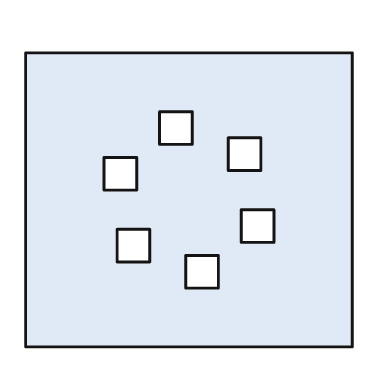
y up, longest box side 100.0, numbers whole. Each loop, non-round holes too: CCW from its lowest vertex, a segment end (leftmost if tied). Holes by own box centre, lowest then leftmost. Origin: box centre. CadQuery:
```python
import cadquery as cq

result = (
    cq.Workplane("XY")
    .moveTo(-50.0, -45.0)
    .lineTo(50.0, -45.0)
    .lineTo(50.0, 45.0)
    .lineTo(-50.0, 45.0)
    .close()
    .moveTo(-1.0, -27.0)
    .lineTo(9.0, -27.0)
    .lineTo(9.0, -17.0)
    .lineTo(-1.0, -17.0)
    .close()
    .moveTo(-22.0, -19.0)
    .lineTo(-12.0, -19.0)
    .lineTo(-12.0, -9.0)
    .lineTo(-22.0, -9.0)
    .close()
    .moveTo(16.0, -13.0)
    .lineTo(26.0, -13.0)
    .lineTo(26.0, -3.0)
    .lineTo(16.0, -3.0)
    .close()
    .moveTo(-26.0, 3.0)
    .lineTo(-16.0, 3.0)
    .lineTo(-16.0, 13.0)
    .lineTo(-26.0, 13.0)
    .close()
    .moveTo(12.0, 9.0)
    .lineTo(22.0, 9.0)
    .lineTo(22.0, 19.0)
    .lineTo(12.0, 19.0)
    .close()
    .moveTo(-9.0, 17.0)
    .lineTo(1.0, 17.0)
    .lineTo(1.0, 27.0)
    .lineTo(-9.0, 27.0)
    .close()
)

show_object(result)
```